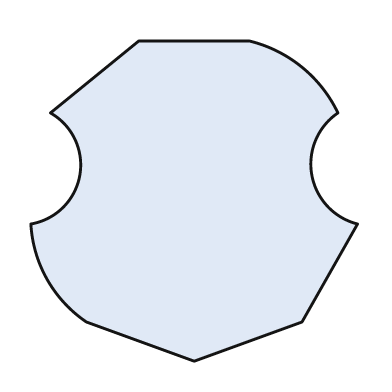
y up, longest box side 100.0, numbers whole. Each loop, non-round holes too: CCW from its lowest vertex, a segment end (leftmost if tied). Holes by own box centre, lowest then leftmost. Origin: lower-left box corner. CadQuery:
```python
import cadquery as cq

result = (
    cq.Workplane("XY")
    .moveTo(50.0, 0.0)
    .lineTo(83.0, 12.0)
    .lineTo(100.0, 42.0)
    .threePointArc((86.0, 57.0), (94.0, 76.0))
    .threePointArc((83.0, 90.0), (67.0, 98.0))
    .lineTo(33.0, 98.0)
    .lineTo(6.0, 76.0)
    .threePointArc((15.0, 57.0), (0.0, 42.0))
    .threePointArc((5.0, 25.0), (17.0, 12.0))
    .close()
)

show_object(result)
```